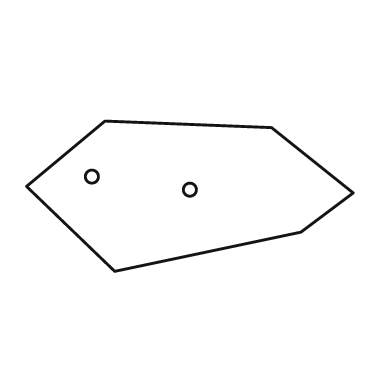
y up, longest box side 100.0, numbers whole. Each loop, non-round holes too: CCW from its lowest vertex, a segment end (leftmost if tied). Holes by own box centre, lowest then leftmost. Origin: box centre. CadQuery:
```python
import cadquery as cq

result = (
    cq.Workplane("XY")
    .moveTo(-23.0, -23.0)
    .lineTo(34.0, -11.0)
    .lineTo(50.0, 1.0)
    .lineTo(25.0, 21.0)
    .lineTo(-26.0, 23.0)
    .lineTo(-50.0, 3.0)
    .close()
    .moveTo(0.0, 2.0)
    .circle(2.0)
    .moveTo(-30.0, 6.0)
    .circle(2.0)
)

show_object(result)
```